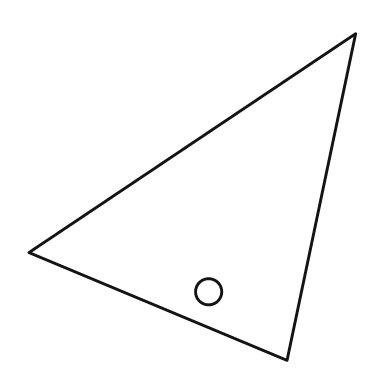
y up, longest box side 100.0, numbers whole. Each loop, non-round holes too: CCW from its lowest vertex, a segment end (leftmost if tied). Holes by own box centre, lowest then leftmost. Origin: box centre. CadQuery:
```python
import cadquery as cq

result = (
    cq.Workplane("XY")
    .moveTo(29.0, -50.0)
    .lineTo(50.0, 50.0)
    .lineTo(-50.0, -17.0)
    .close()
    .moveTo(5.0, -29.0)
    .circle(4.0)
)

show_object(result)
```